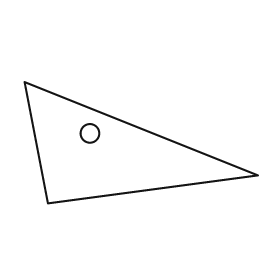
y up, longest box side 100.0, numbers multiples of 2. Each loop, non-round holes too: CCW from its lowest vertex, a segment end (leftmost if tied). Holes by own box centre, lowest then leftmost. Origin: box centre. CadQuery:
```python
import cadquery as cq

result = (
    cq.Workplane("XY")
    .moveTo(-40.0, -26.0)
    .lineTo(50.0, -14.0)
    .lineTo(-50.0, 26.0)
    .close()
    .moveTo(-22.0, 4.0)
    .circle(4.0)
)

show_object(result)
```